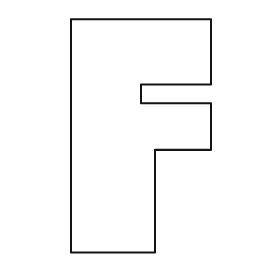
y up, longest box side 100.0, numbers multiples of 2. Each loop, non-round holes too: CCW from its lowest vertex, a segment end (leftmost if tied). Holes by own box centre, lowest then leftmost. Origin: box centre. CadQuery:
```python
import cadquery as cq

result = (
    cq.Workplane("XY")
    .moveTo(-30.0, -50.0)
    .lineTo(6.0, -50.0)
    .lineTo(6.0, -6.0)
    .lineTo(30.0, -6.0)
    .lineTo(30.0, 14.0)
    .lineTo(0.0, 14.0)
    .lineTo(0.0, 22.0)
    .lineTo(30.0, 22.0)
    .lineTo(30.0, 50.0)
    .lineTo(-30.0, 50.0)
    .close()
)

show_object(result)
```